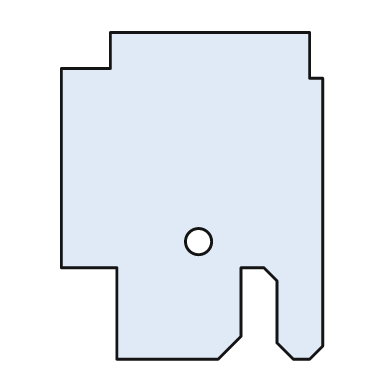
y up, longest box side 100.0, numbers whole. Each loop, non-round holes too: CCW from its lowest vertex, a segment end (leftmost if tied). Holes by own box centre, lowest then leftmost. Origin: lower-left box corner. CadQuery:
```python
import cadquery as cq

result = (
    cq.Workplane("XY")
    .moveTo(17.0, 0.0)
    .lineTo(48.0, 0.0)
    .lineTo(55.0, 7.0)
    .lineTo(55.0, 28.0)
    .lineTo(62.0, 28.0)
    .lineTo(66.0, 24.0)
    .lineTo(66.0, 5.0)
    .lineTo(71.0, 0.0)
    .lineTo(76.0, 0.0)
    .lineTo(80.0, 4.0)
    .lineTo(80.0, 86.0)
    .lineTo(76.0, 86.0)
    .lineTo(76.0, 100.0)
    .lineTo(15.0, 100.0)
    .lineTo(15.0, 89.0)
    .lineTo(0.0, 89.0)
    .lineTo(0.0, 28.0)
    .lineTo(17.0, 28.0)
    .close()
    .moveTo(42.0, 36.0)
    .circle(4.0)
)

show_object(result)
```